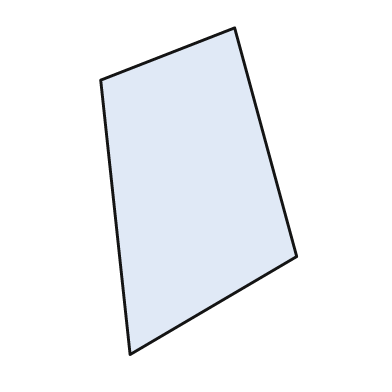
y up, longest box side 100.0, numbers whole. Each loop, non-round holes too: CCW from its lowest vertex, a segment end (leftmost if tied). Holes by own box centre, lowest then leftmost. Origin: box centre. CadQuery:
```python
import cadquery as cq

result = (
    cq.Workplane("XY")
    .moveTo(-21.0, -50.0)
    .lineTo(30.0, -20.0)
    .lineTo(11.0, 50.0)
    .lineTo(-30.0, 34.0)
    .close()
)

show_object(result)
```